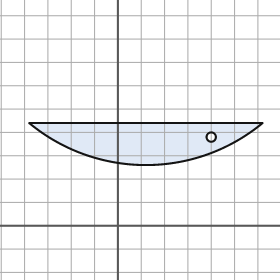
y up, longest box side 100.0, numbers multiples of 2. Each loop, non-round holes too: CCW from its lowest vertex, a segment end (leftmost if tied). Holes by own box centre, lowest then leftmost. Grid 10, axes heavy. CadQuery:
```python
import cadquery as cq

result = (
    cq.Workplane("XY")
    .moveTo(-38.0, 44.0)
    .threePointArc((12.0, 26.0), (62.0, 44.0))
    .close()
    .moveTo(40.0, 38.0)
    .circle(2.0)
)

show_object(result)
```